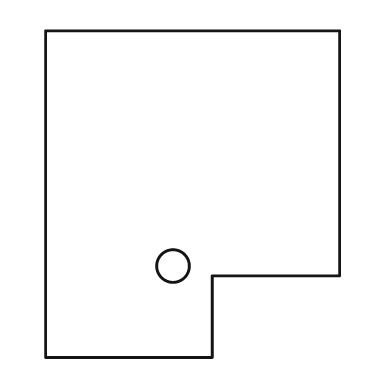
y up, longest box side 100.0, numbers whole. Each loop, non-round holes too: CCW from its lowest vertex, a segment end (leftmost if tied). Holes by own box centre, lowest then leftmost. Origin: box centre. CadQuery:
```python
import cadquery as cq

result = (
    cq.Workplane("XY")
    .moveTo(-45.0, -50.0)
    .lineTo(6.0, -50.0)
    .lineTo(6.0, -25.0)
    .lineTo(45.0, -25.0)
    .lineTo(45.0, 50.0)
    .lineTo(-45.0, 50.0)
    .close()
    .moveTo(-6.0, -22.0)
    .circle(5.0)
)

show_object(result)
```